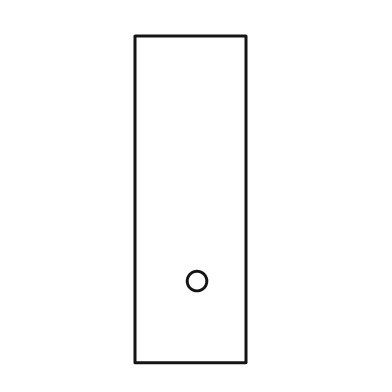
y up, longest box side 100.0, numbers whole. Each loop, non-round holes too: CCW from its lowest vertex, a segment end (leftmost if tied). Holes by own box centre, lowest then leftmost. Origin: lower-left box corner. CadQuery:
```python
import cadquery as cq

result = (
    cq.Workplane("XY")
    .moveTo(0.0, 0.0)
    .lineTo(34.0, 0.0)
    .lineTo(34.0, 100.0)
    .lineTo(0.0, 100.0)
    .close()
    .moveTo(19.0, 25.0)
    .circle(3.0)
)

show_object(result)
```